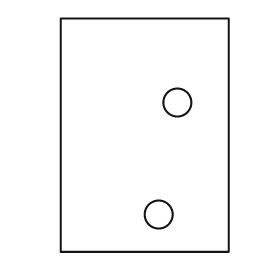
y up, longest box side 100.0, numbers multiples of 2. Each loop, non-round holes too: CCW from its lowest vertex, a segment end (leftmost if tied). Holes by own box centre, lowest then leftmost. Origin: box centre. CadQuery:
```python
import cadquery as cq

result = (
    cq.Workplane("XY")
    .moveTo(-36.0, -50.0)
    .lineTo(36.0, -50.0)
    .lineTo(36.0, 50.0)
    .lineTo(-36.0, 50.0)
    .close()
    .moveTo(6.0, -34.0)
    .circle(6.0)
    .moveTo(14.0, 14.0)
    .circle(6.0)
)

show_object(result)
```